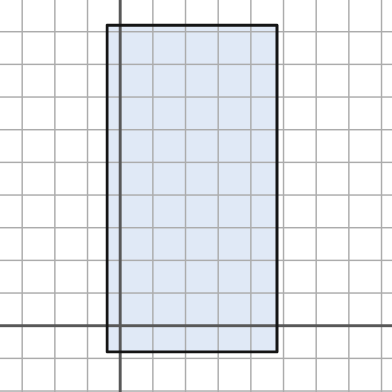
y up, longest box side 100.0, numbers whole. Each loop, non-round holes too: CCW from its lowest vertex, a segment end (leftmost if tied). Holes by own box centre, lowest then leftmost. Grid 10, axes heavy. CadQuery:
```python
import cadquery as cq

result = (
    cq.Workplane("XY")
    .moveTo(-4.0, -8.0)
    .lineTo(48.0, -8.0)
    .lineTo(48.0, 92.0)
    .lineTo(-4.0, 92.0)
    .close()
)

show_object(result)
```